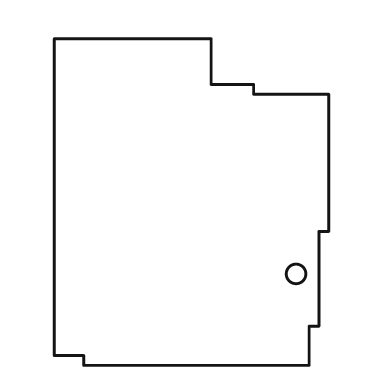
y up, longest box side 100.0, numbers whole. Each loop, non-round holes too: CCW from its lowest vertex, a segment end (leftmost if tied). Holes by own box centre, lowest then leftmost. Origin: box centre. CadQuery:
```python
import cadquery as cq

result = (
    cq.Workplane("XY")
    .moveTo(-33.0, -50.0)
    .lineTo(36.0, -50.0)
    .lineTo(36.0, -38.0)
    .lineTo(39.0, -38.0)
    .lineTo(39.0, -9.0)
    .lineTo(42.0, -9.0)
    .lineTo(42.0, 33.0)
    .lineTo(19.0, 33.0)
    .lineTo(19.0, 36.0)
    .lineTo(6.0, 36.0)
    .lineTo(6.0, 50.0)
    .lineTo(-42.0, 50.0)
    .lineTo(-42.0, -47.0)
    .lineTo(-33.0, -47.0)
    .close()
    .moveTo(32.0, -22.0)
    .circle(3.0)
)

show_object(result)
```